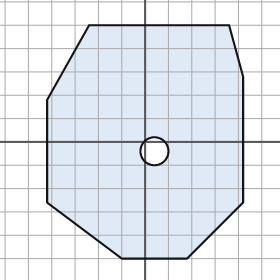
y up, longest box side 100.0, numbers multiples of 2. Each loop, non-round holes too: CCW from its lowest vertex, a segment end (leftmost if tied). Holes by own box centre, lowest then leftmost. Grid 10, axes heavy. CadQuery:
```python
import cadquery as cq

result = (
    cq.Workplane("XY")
    .moveTo(-10.0, -50.0)
    .lineTo(18.0, -50.0)
    .lineTo(42.0, -26.0)
    .lineTo(42.0, 28.0)
    .lineTo(36.0, 50.0)
    .lineTo(-24.0, 50.0)
    .lineTo(-42.0, 18.0)
    .lineTo(-42.0, -26.0)
    .close()
    .moveTo(4.0, -4.0)
    .circle(6.0)
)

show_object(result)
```